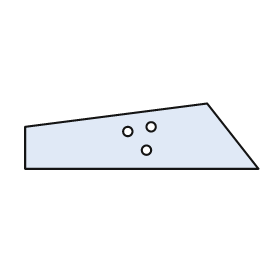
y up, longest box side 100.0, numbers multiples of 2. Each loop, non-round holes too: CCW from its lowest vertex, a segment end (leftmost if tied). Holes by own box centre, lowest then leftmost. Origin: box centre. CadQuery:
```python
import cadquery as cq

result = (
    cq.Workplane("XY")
    .moveTo(-50.0, -14.0)
    .lineTo(50.0, -14.0)
    .lineTo(28.0, 14.0)
    .lineTo(-50.0, 4.0)
    .close()
    .moveTo(2.0, -6.0)
    .circle(2.0)
    .moveTo(-6.0, 2.0)
    .circle(2.0)
    .moveTo(4.0, 4.0)
    .circle(2.0)
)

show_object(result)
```